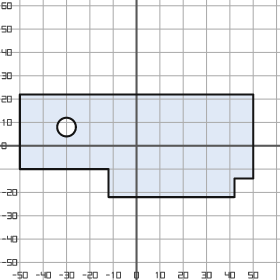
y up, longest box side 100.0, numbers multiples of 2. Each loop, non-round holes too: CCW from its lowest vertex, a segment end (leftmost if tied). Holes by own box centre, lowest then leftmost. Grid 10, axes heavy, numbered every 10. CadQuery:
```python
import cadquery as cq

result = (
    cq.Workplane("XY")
    .moveTo(-12.0, -22.0)
    .lineTo(42.0, -22.0)
    .lineTo(42.0, -14.0)
    .lineTo(50.0, -14.0)
    .lineTo(50.0, 22.0)
    .lineTo(-50.0, 22.0)
    .lineTo(-50.0, -10.0)
    .lineTo(-12.0, -10.0)
    .close()
    .moveTo(-30.0, 8.0)
    .circle(4.0)
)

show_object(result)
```